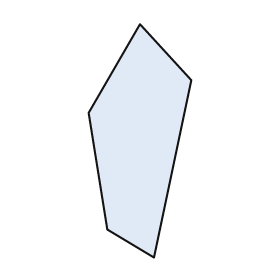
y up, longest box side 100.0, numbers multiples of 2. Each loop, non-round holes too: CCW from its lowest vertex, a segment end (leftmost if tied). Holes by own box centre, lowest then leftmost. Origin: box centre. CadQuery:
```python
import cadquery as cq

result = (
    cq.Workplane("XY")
    .moveTo(6.0, -50.0)
    .lineTo(22.0, 26.0)
    .lineTo(0.0, 50.0)
    .lineTo(-22.0, 12.0)
    .lineTo(-14.0, -38.0)
    .close()
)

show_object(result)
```